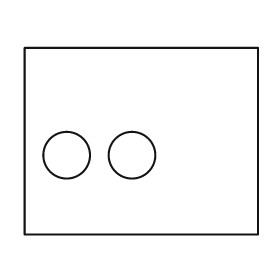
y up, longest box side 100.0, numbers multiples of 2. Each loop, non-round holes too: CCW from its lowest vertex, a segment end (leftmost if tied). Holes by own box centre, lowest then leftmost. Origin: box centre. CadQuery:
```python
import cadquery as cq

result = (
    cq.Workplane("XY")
    .moveTo(-50.0, -40.0)
    .lineTo(50.0, -40.0)
    .lineTo(50.0, 40.0)
    .lineTo(-50.0, 40.0)
    .close()
    .moveTo(-32.0, -6.0)
    .circle(10.0)
    .moveTo(-4.0, -6.0)
    .circle(10.0)
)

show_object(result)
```